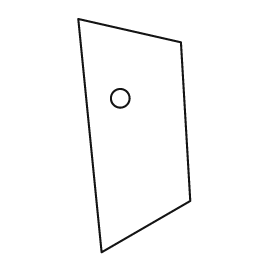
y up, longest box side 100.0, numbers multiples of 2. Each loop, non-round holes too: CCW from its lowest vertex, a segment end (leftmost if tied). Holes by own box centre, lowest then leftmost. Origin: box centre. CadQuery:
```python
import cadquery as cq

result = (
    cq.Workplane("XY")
    .moveTo(-14.0, -50.0)
    .lineTo(24.0, -28.0)
    .lineTo(20.0, 40.0)
    .lineTo(-24.0, 50.0)
    .close()
    .moveTo(-6.0, 16.0)
    .circle(4.0)
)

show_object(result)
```